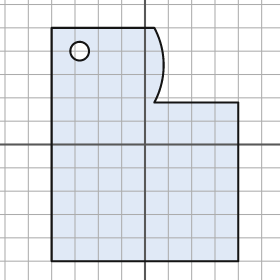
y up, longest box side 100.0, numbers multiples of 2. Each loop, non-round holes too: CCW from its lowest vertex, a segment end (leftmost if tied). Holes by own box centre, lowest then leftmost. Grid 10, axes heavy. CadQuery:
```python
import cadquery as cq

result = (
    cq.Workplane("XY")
    .moveTo(-40.0, -50.0)
    .lineTo(40.0, -50.0)
    .lineTo(40.0, 18.0)
    .lineTo(4.0, 18.0)
    .threePointArc((8.0, 34.0), (4.0, 50.0))
    .lineTo(-40.0, 50.0)
    .close()
    .moveTo(-28.0, 40.0)
    .circle(4.0)
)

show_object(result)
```